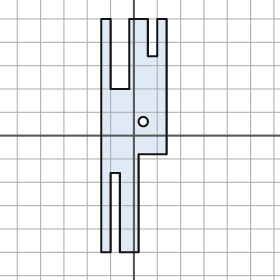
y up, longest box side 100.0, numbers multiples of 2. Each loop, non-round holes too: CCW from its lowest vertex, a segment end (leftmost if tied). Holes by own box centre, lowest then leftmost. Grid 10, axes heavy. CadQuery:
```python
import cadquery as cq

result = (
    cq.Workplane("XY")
    .moveTo(-14.0, -50.0)
    .lineTo(-10.0, -50.0)
    .lineTo(-10.0, -16.0)
    .lineTo(-6.0, -16.0)
    .lineTo(-6.0, -50.0)
    .lineTo(2.0, -50.0)
    .lineTo(2.0, -8.0)
    .lineTo(14.0, -8.0)
    .lineTo(14.0, 50.0)
    .lineTo(10.0, 50.0)
    .lineTo(10.0, 34.0)
    .lineTo(6.0, 34.0)
    .lineTo(6.0, 50.0)
    .lineTo(-2.0, 50.0)
    .lineTo(-2.0, 20.0)
    .lineTo(-10.0, 20.0)
    .lineTo(-10.0, 50.0)
    .lineTo(-14.0, 50.0)
    .close()
    .moveTo(4.0, 6.0)
    .circle(2.0)
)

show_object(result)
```